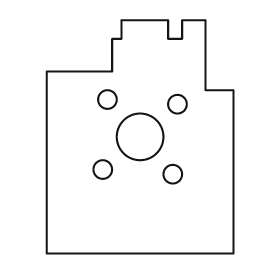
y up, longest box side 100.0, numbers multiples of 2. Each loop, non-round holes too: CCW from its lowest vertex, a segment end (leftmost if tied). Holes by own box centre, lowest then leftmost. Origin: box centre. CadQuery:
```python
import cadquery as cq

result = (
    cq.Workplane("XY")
    .moveTo(-40.0, -50.0)
    .lineTo(40.0, -50.0)
    .lineTo(40.0, 20.0)
    .lineTo(28.0, 20.0)
    .lineTo(28.0, 50.0)
    .lineTo(18.0, 50.0)
    .lineTo(18.0, 42.0)
    .lineTo(12.0, 42.0)
    .lineTo(12.0, 50.0)
    .lineTo(-8.0, 50.0)
    .lineTo(-8.0, 42.0)
    .lineTo(-12.0, 42.0)
    .lineTo(-12.0, 28.0)
    .lineTo(-40.0, 28.0)
    .close()
    .moveTo(14.0, -16.0)
    .circle(4.0)
    .moveTo(-16.0, -14.0)
    .circle(4.0)
    .moveTo(0.0, 0.0)
    .circle(10.0)
    .moveTo(16.0, 14.0)
    .circle(4.0)
    .moveTo(-14.0, 16.0)
    .circle(4.0)
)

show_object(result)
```